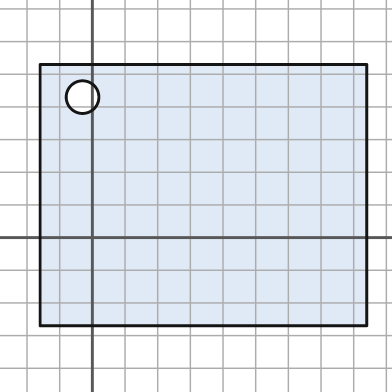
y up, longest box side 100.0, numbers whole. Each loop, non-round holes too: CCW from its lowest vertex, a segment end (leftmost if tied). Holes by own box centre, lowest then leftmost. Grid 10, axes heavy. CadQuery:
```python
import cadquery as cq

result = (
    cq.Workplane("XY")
    .moveTo(-16.0, -27.0)
    .lineTo(84.0, -27.0)
    .lineTo(84.0, 53.0)
    .lineTo(-16.0, 53.0)
    .close()
    .moveTo(-3.0, 43.0)
    .circle(5.0)
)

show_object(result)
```